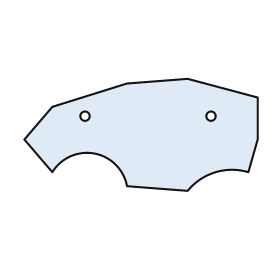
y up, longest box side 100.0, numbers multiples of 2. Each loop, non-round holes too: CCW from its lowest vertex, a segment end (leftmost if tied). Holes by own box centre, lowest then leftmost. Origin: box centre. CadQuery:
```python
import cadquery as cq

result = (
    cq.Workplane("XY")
    .moveTo(20.0, -24.0)
    .threePointArc((32.0, -16.0), (46.0, -16.0))
    .lineTo(50.0, -2.0)
    .lineTo(50.0, 16.0)
    .lineTo(20.0, 24.0)
    .lineTo(-6.0, 22.0)
    .lineTo(-38.0, 12.0)
    .lineTo(-50.0, -2.0)
    .lineTo(-38.0, -16.0)
    .threePointArc((-20.0, -8.0), (-6.0, -22.0))
    .close()
    .moveTo(-24.0, 8.0)
    .circle(2.0)
    .moveTo(30.0, 8.0)
    .circle(2.0)
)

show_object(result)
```